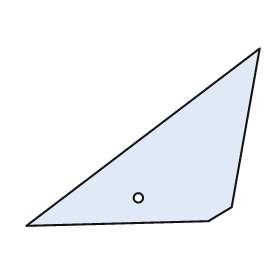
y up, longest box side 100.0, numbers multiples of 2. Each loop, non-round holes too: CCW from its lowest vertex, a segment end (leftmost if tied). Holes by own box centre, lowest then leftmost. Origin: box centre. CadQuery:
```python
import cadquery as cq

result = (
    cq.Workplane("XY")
    .moveTo(-50.0, -38.0)
    .lineTo(28.0, -36.0)
    .lineTo(38.0, -30.0)
    .lineTo(50.0, 38.0)
    .close()
    .moveTo(-2.0, -26.0)
    .circle(2.0)
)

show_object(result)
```